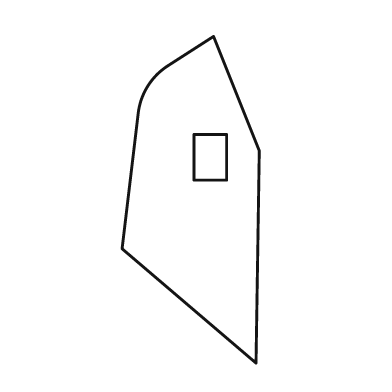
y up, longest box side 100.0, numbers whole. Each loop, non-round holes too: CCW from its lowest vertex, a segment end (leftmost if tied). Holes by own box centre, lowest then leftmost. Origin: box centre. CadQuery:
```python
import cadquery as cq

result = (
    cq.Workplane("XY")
    .moveTo(20.0, -50.0)
    .lineTo(21.0, 15.0)
    .lineTo(7.0, 50.0)
    .lineTo(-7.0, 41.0)
    .threePointArc((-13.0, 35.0), (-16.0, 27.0))
    .lineTo(-21.0, -15.0)
    .close()
    .moveTo(1.0, 6.0)
    .lineTo(11.0, 6.0)
    .lineTo(11.0, 20.0)
    .lineTo(1.0, 20.0)
    .close()
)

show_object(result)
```